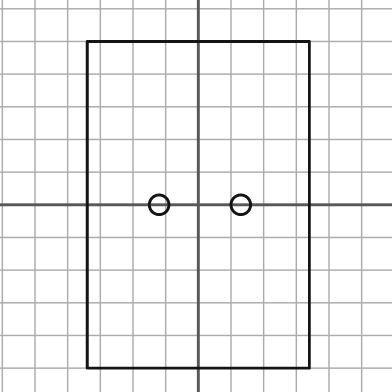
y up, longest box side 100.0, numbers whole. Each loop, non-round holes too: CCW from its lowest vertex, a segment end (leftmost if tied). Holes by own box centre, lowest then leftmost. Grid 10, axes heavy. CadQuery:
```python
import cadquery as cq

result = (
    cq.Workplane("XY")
    .moveTo(-34.0, -50.0)
    .lineTo(34.0, -50.0)
    .lineTo(34.0, 50.0)
    .lineTo(-34.0, 50.0)
    .close()
    .moveTo(-12.0, 0.0)
    .circle(3.0)
    .moveTo(13.0, 0.0)
    .circle(3.0)
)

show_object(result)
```